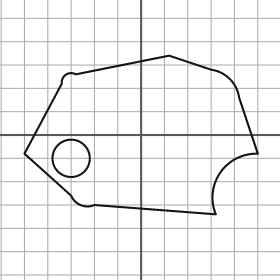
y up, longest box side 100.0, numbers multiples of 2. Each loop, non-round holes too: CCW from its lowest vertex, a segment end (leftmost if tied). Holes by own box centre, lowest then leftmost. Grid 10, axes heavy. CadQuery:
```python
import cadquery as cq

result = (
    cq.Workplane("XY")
    .moveTo(32.0, -34.0)
    .threePointArc((34.0, -16.0), (50.0, -8.0))
    .lineTo(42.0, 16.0)
    .threePointArc((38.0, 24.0), (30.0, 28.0))
    .lineTo(12.0, 34.0)
    .lineTo(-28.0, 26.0)
    .threePointArc((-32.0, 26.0), (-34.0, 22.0))
    .lineTo(-50.0, -8.0)
    .lineTo(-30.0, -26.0)
    .threePointArc((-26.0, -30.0), (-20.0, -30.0))
    .close()
    .moveTo(-30.0, -10.0)
    .circle(8.0)
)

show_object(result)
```